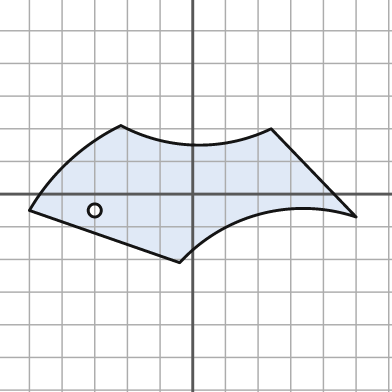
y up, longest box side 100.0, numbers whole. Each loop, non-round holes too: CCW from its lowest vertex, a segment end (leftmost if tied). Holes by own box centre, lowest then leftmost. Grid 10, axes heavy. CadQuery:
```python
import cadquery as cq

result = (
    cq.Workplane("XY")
    .moveTo(-4.0, -21.0)
    .threePointArc((21.0, -6.0), (50.0, -7.0))
    .lineTo(24.0, 20.0)
    .threePointArc((1.0, 15.0), (-22.0, 21.0))
    .threePointArc((-38.0, 10.0), (-50.0, -5.0))
    .close()
    .moveTo(-30.0, -5.0)
    .circle(2.0)
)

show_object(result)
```